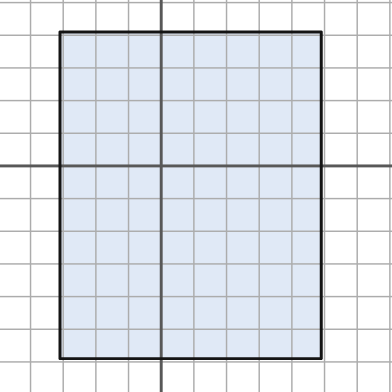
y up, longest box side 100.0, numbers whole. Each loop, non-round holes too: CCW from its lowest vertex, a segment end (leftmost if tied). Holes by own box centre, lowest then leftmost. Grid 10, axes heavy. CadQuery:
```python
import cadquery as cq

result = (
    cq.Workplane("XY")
    .moveTo(-31.0, -59.0)
    .lineTo(49.0, -59.0)
    .lineTo(49.0, 41.0)
    .lineTo(-31.0, 41.0)
    .close()
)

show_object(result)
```